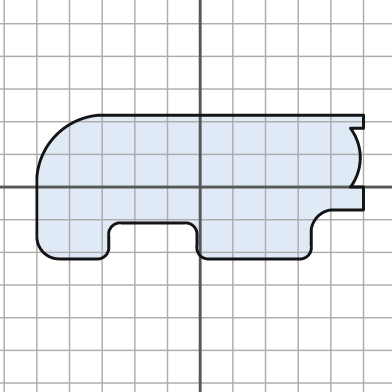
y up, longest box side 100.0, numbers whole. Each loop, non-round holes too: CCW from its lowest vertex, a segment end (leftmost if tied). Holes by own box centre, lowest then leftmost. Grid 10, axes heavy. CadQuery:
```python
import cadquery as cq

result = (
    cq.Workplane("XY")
    .moveTo(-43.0, -22.0)
    .lineTo(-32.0, -22.0)
    .threePointArc((-29.0, -21.0), (-28.0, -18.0))
    .lineTo(-28.0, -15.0)
    .threePointArc((-27.0, -12.0), (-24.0, -11.0))
    .lineTo(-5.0, -11.0)
    .threePointArc((-2.0, -12.0), (-1.0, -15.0))
    .lineTo(-1.0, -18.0)
    .threePointArc((0.0, -21.0), (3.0, -22.0))
    .lineTo(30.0, -22.0)
    .threePointArc((33.0, -21.0), (34.0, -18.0))
    .lineTo(34.0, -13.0)
    .threePointArc((36.0, -9.0), (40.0, -7.0))
    .lineTo(50.0, -7.0)
    .lineTo(50.0, 0.0)
    .lineTo(46.0, 0.0)
    .threePointArc((49.0, 9.0), (46.0, 18.0))
    .lineTo(50.0, 18.0)
    .lineTo(50.0, 22.0)
    .lineTo(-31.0, 22.0)
    .threePointArc((-44.0, 16.0), (-50.0, 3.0))
    .lineTo(-50.0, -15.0)
    .threePointArc((-48.0, -20.0), (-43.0, -22.0))
    .close()
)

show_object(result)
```